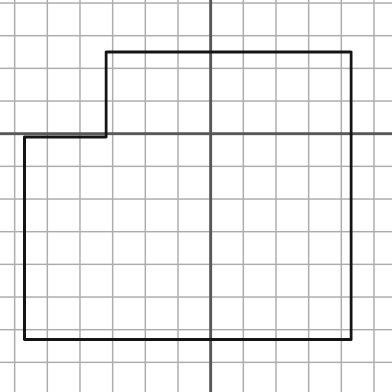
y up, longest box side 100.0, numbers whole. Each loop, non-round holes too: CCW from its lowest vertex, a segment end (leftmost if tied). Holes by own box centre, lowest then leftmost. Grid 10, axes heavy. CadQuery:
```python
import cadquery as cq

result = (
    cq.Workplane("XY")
    .moveTo(-57.0, -63.0)
    .lineTo(43.0, -63.0)
    .lineTo(43.0, 25.0)
    .lineTo(-32.0, 25.0)
    .lineTo(-32.0, -1.0)
    .lineTo(-57.0, -1.0)
    .close()
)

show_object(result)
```